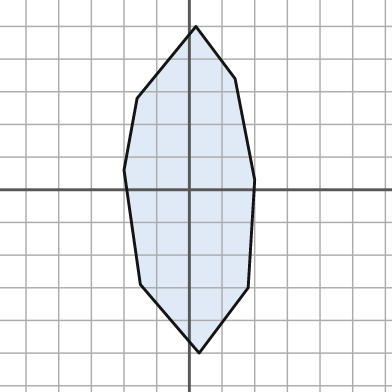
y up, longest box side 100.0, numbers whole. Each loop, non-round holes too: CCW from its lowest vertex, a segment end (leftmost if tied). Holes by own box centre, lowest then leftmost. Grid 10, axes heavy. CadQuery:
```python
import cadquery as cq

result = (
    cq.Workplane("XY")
    .moveTo(3.0, -50.0)
    .lineTo(18.0, -30.0)
    .lineTo(20.0, 3.0)
    .lineTo(14.0, 34.0)
    .lineTo(2.0, 50.0)
    .lineTo(-16.0, 28.0)
    .lineTo(-20.0, 6.0)
    .lineTo(-15.0, -29.0)
    .close()
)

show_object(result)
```